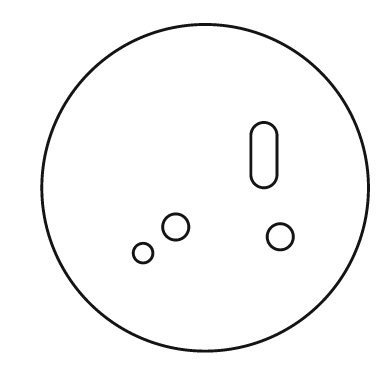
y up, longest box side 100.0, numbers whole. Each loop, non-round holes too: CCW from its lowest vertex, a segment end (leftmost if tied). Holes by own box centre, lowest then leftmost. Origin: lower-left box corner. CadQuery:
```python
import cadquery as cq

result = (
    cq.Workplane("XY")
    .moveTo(50.0, 50.0)
    .circle(50.0)
    .moveTo(31.0, 30.0)
    .circle(3.0)
    .moveTo(73.0, 35.0)
    .circle(4.0)
    .moveTo(41.0, 38.0)
    .circle(4.0)
    .moveTo(64.0, 54.0)
    .threePointArc((68.0, 50.0), (72.0, 54.0))
    .lineTo(72.0, 66.0)
    .threePointArc((68.0, 70.0), (64.0, 66.0))
    .close()
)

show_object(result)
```